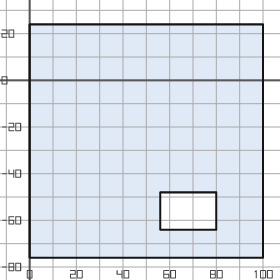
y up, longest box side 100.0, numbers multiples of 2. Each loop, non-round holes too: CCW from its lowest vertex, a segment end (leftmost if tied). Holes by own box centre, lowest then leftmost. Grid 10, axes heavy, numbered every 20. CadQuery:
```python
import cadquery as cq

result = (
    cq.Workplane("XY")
    .moveTo(0.0, -76.0)
    .lineTo(100.0, -76.0)
    .lineTo(100.0, 24.0)
    .lineTo(0.0, 24.0)
    .close()
    .moveTo(56.0, -64.0)
    .lineTo(80.0, -64.0)
    .lineTo(80.0, -48.0)
    .lineTo(56.0, -48.0)
    .close()
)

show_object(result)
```